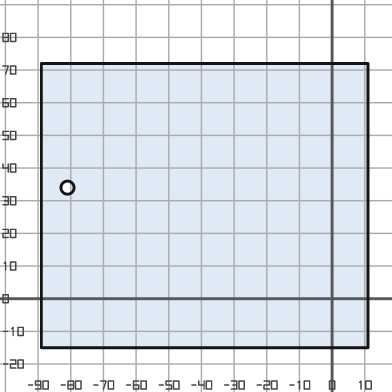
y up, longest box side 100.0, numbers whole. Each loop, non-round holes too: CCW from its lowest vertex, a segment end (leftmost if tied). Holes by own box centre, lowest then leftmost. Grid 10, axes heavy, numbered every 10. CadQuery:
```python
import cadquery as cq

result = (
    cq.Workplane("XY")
    .moveTo(-89.0, -15.0)
    .lineTo(11.0, -15.0)
    .lineTo(11.0, 72.0)
    .lineTo(-89.0, 72.0)
    .close()
    .moveTo(-81.0, 34.0)
    .circle(2.0)
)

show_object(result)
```